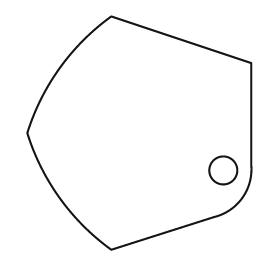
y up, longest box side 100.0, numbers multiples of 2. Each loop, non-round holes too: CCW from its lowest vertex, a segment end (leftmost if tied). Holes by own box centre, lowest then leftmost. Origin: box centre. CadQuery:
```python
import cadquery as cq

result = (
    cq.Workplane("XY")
    .moveTo(-12.0, -50.0)
    .lineTo(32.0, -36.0)
    .threePointArc((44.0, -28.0), (48.0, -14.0))
    .lineTo(48.0, 30.0)
    .lineTo(-12.0, 50.0)
    .threePointArc((-34.0, 28.0), (-48.0, 0.0))
    .threePointArc((-34.0, -28.0), (-12.0, -50.0))
    .close()
    .moveTo(36.0, -16.0)
    .circle(6.0)
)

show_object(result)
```